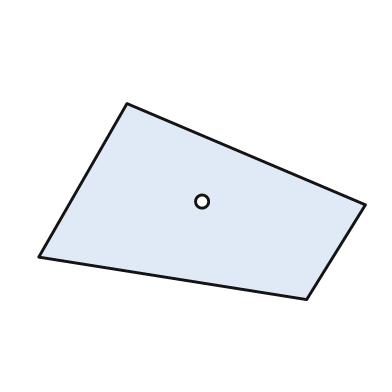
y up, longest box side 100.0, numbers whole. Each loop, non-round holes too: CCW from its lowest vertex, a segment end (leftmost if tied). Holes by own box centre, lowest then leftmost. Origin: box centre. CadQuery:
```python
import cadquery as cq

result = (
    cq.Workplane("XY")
    .moveTo(32.0, -30.0)
    .lineTo(50.0, -1.0)
    .lineTo(-23.0, 30.0)
    .lineTo(-50.0, -17.0)
    .close()
    .moveTo(0.0, 0.0)
    .circle(2.0)
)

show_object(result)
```